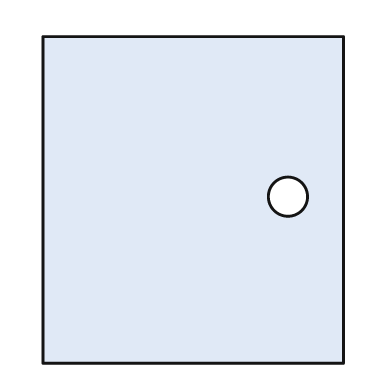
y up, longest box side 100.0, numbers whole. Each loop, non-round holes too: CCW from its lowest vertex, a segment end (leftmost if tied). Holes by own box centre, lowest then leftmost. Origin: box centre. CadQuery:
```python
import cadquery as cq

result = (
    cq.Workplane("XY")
    .moveTo(-46.0, -50.0)
    .lineTo(46.0, -50.0)
    .lineTo(46.0, 50.0)
    .lineTo(-46.0, 50.0)
    .close()
    .moveTo(29.0, 1.0)
    .circle(6.0)
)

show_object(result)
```